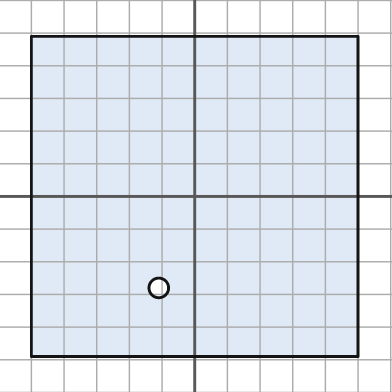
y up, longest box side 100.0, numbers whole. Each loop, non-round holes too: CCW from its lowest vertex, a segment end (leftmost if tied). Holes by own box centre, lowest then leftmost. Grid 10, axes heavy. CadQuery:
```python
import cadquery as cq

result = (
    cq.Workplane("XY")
    .moveTo(-50.0, -49.0)
    .lineTo(50.0, -49.0)
    .lineTo(50.0, 49.0)
    .lineTo(-50.0, 49.0)
    .close()
    .moveTo(-11.0, -28.0)
    .circle(3.0)
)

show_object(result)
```